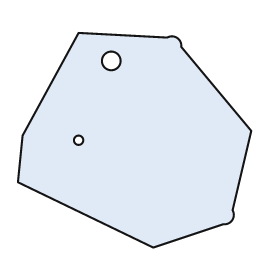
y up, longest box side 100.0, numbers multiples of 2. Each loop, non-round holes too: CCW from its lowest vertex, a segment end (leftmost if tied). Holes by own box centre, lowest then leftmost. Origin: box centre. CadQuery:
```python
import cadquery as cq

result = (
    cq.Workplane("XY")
    .moveTo(8.0, -46.0)
    .lineTo(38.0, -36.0)
    .threePointArc((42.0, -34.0), (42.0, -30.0))
    .lineTo(50.0, 4.0)
    .lineTo(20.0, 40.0)
    .threePointArc((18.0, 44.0), (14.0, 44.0))
    .lineTo(-24.0, 46.0)
    .lineTo(-48.0, 2.0)
    .lineTo(-50.0, -18.0)
    .close()
    .moveTo(-24.0, 0.0)
    .circle(2.0)
    .moveTo(-10.0, 34.0)
    .circle(4.0)
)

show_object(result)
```